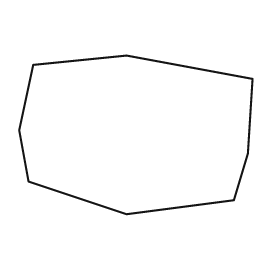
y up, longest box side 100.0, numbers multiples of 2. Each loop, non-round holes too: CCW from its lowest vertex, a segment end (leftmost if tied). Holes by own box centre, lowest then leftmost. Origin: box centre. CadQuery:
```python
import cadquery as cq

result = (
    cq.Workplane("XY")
    .moveTo(-4.0, -34.0)
    .lineTo(42.0, -28.0)
    .lineTo(48.0, -8.0)
    .lineTo(50.0, 24.0)
    .lineTo(-4.0, 34.0)
    .lineTo(-44.0, 30.0)
    .lineTo(-50.0, 2.0)
    .lineTo(-46.0, -20.0)
    .close()
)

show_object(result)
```